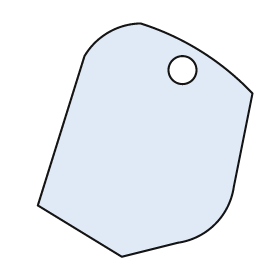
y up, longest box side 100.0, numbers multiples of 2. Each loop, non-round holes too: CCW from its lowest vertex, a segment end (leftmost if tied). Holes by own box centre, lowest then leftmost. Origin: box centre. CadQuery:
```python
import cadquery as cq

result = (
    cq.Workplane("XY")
    .moveTo(-10.0, -50.0)
    .lineTo(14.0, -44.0)
    .threePointArc((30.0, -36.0), (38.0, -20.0))
    .lineTo(46.0, 20.0)
    .threePointArc((24.0, 38.0), (-2.0, 50.0))
    .threePointArc((-16.0, 46.0), (-26.0, 36.0))
    .lineTo(-46.0, -28.0)
    .close()
    .moveTo(16.0, 30.0)
    .circle(6.0)
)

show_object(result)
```